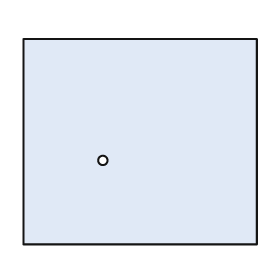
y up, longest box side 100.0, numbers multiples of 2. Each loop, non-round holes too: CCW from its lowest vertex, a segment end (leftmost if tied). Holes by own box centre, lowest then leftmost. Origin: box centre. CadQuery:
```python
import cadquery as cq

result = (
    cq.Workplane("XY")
    .moveTo(-50.0, -44.0)
    .lineTo(50.0, -44.0)
    .lineTo(50.0, 44.0)
    .lineTo(-50.0, 44.0)
    .close()
    .moveTo(-16.0, -8.0)
    .circle(2.0)
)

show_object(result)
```